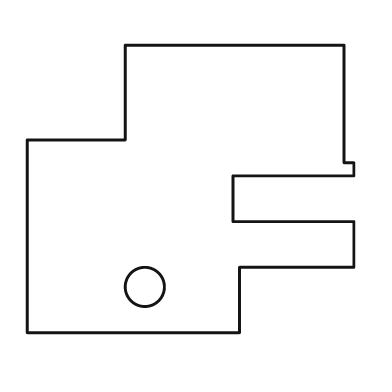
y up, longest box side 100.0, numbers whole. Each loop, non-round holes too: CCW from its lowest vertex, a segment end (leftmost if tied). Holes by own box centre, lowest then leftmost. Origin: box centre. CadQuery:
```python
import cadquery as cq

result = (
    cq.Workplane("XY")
    .moveTo(-50.0, -44.0)
    .lineTo(15.0, -44.0)
    .lineTo(15.0, -24.0)
    .lineTo(50.0, -24.0)
    .lineTo(50.0, -10.0)
    .lineTo(13.0, -10.0)
    .lineTo(13.0, 4.0)
    .lineTo(50.0, 4.0)
    .lineTo(50.0, 8.0)
    .lineTo(47.0, 8.0)
    .lineTo(47.0, 44.0)
    .lineTo(-20.0, 44.0)
    .lineTo(-20.0, 15.0)
    .lineTo(-50.0, 15.0)
    .close()
    .moveTo(-14.0, -30.0)
    .circle(6.0)
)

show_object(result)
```